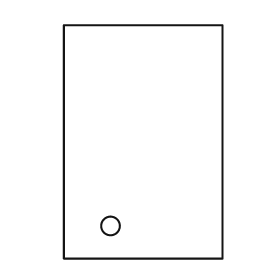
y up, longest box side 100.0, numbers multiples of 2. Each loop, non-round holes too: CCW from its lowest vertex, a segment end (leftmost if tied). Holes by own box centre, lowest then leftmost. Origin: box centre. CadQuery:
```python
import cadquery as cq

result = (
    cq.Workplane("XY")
    .moveTo(-34.0, -50.0)
    .lineTo(34.0, -50.0)
    .lineTo(34.0, 50.0)
    .lineTo(-34.0, 50.0)
    .close()
    .moveTo(-14.0, -36.0)
    .circle(4.0)
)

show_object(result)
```